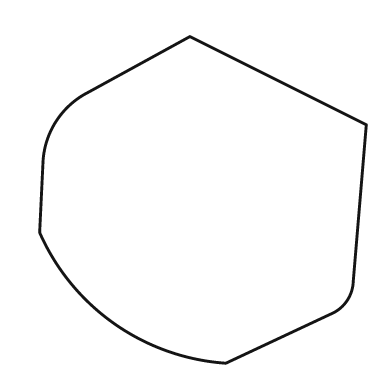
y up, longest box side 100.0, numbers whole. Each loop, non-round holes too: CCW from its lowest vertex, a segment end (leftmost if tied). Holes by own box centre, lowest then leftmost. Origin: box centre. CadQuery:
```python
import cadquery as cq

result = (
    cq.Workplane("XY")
    .moveTo(7.0, -50.0)
    .lineTo(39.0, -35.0)
    .threePointArc((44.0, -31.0), (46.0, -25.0))
    .lineTo(50.0, 23.0)
    .lineTo(-4.0, 50.0)
    .lineTo(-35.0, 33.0)
    .threePointArc((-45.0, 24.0), (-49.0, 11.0))
    .lineTo(-50.0, -10.0)
    .threePointArc((-27.0, -38.0), (7.0, -50.0))
    .close()
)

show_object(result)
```